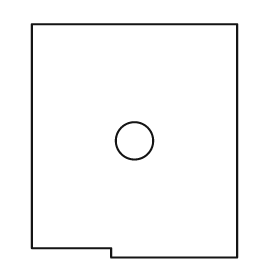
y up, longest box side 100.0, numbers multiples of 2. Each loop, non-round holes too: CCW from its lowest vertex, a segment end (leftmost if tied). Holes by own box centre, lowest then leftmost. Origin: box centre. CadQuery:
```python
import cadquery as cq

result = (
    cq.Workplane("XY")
    .moveTo(-10.0, -50.0)
    .lineTo(44.0, -50.0)
    .lineTo(44.0, 50.0)
    .lineTo(-44.0, 50.0)
    .lineTo(-44.0, -46.0)
    .lineTo(-10.0, -46.0)
    .close()
    .moveTo(0.0, 0.0)
    .circle(8.0)
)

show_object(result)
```